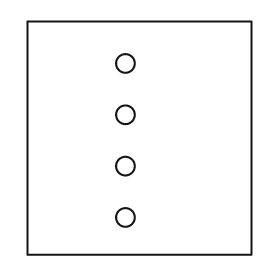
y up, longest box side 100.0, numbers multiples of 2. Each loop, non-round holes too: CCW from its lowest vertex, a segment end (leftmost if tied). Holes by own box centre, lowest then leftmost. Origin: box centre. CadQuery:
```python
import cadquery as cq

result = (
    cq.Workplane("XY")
    .moveTo(-48.0, -50.0)
    .lineTo(48.0, -50.0)
    .lineTo(48.0, 50.0)
    .lineTo(-48.0, 50.0)
    .close()
    .moveTo(-6.0, -34.0)
    .circle(4.0)
    .moveTo(-6.0, -12.0)
    .circle(4.0)
    .moveTo(-6.0, 10.0)
    .circle(4.0)
    .moveTo(-6.0, 32.0)
    .circle(4.0)
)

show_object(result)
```